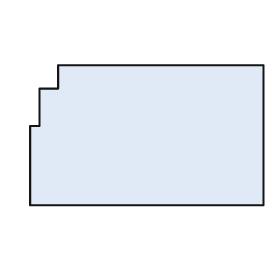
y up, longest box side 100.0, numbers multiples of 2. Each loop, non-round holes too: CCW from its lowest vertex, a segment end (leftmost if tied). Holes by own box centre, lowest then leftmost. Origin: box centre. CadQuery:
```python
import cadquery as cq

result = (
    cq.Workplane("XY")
    .moveTo(-50.0, -30.0)
    .lineTo(50.0, -30.0)
    .lineTo(50.0, 30.0)
    .lineTo(-38.0, 30.0)
    .lineTo(-38.0, 20.0)
    .lineTo(-46.0, 20.0)
    .lineTo(-46.0, 4.0)
    .lineTo(-50.0, 4.0)
    .close()
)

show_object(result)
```